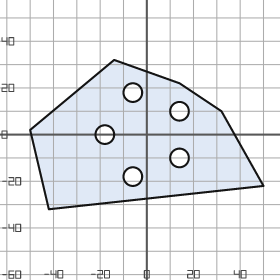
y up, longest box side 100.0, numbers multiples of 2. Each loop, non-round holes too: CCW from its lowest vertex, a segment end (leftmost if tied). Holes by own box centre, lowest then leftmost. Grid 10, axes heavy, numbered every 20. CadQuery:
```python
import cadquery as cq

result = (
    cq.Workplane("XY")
    .moveTo(-42.0, -32.0)
    .lineTo(50.0, -22.0)
    .lineTo(32.0, 10.0)
    .lineTo(14.0, 22.0)
    .lineTo(-14.0, 32.0)
    .lineTo(-50.0, 2.0)
    .close()
    .moveTo(-6.0, -18.0)
    .circle(4.0)
    .moveTo(14.0, -10.0)
    .circle(4.0)
    .moveTo(-18.0, 0.0)
    .circle(4.0)
    .moveTo(14.0, 10.0)
    .circle(4.0)
    .moveTo(-6.0, 18.0)
    .circle(4.0)
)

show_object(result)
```